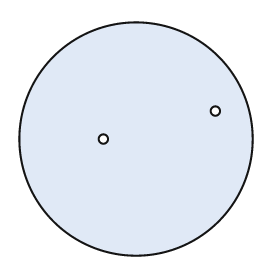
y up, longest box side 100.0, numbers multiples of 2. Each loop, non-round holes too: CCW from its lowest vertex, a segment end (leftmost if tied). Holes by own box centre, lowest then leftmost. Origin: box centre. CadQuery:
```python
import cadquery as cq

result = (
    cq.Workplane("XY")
    .moveTo(0.0, 0.0)
    .circle(50.0)
    .moveTo(-14.0, 0.0)
    .circle(2.0)
    .moveTo(34.0, 12.0)
    .circle(2.0)
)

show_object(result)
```